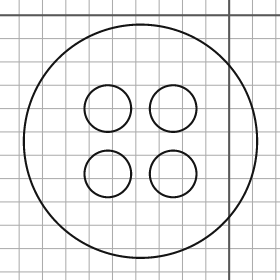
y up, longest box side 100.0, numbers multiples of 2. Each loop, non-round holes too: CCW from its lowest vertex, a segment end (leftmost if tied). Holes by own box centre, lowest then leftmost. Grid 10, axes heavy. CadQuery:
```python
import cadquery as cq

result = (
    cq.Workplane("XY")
    .moveTo(-38.0, -54.0)
    .circle(50.0)
    .moveTo(-52.0, -68.0)
    .circle(10.0)
    .moveTo(-24.0, -68.0)
    .circle(10.0)
    .moveTo(-52.0, -40.0)
    .circle(10.0)
    .moveTo(-24.0, -40.0)
    .circle(10.0)
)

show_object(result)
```